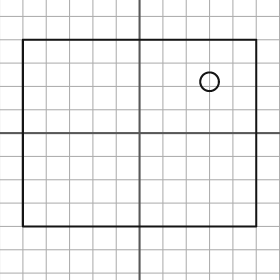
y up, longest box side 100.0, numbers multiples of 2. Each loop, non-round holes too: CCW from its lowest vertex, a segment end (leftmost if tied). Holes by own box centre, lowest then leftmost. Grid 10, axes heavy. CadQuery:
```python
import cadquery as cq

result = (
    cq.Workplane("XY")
    .moveTo(-50.0, -40.0)
    .lineTo(50.0, -40.0)
    .lineTo(50.0, 40.0)
    .lineTo(-50.0, 40.0)
    .close()
    .moveTo(30.0, 22.0)
    .circle(4.0)
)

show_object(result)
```